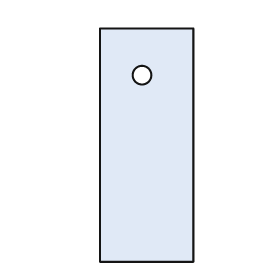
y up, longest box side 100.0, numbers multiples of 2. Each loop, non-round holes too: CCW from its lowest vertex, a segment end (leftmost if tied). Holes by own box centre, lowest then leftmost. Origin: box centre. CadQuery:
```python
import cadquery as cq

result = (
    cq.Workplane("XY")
    .moveTo(-20.0, -50.0)
    .lineTo(20.0, -50.0)
    .lineTo(20.0, 50.0)
    .lineTo(-20.0, 50.0)
    .close()
    .moveTo(-2.0, 30.0)
    .circle(4.0)
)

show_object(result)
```